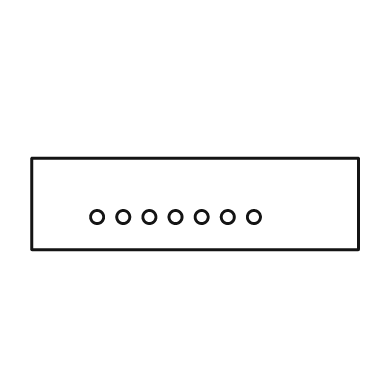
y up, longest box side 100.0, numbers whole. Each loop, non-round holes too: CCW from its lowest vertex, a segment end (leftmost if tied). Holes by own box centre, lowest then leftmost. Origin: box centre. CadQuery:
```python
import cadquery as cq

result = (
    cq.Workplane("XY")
    .moveTo(-50.0, -14.0)
    .lineTo(50.0, -14.0)
    .lineTo(50.0, 14.0)
    .lineTo(-50.0, 14.0)
    .close()
    .moveTo(-30.0, -4.0)
    .circle(2.0)
    .moveTo(-22.0, -4.0)
    .circle(2.0)
    .moveTo(-14.0, -4.0)
    .circle(2.0)
    .moveTo(-6.0, -4.0)
    .circle(2.0)
    .moveTo(2.0, -4.0)
    .circle(2.0)
    .moveTo(10.0, -4.0)
    .circle(2.0)
    .moveTo(18.0, -4.0)
    .circle(2.0)
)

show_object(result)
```